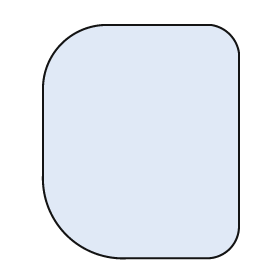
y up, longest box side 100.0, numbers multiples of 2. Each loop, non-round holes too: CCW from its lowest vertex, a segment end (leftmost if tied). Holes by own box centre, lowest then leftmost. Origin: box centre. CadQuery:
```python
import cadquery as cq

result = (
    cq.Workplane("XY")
    .moveTo(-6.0, -50.0)
    .lineTo(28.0, -50.0)
    .threePointArc((38.0, -46.0), (42.0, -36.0))
    .lineTo(42.0, 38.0)
    .threePointArc((38.0, 46.0), (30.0, 50.0))
    .lineTo(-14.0, 50.0)
    .threePointArc((-34.0, 42.0), (-42.0, 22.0))
    .lineTo(-42.0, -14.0)
    .threePointArc((-32.0, -40.0), (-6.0, -50.0))
    .close()
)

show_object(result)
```